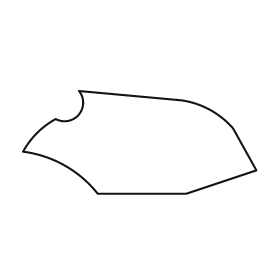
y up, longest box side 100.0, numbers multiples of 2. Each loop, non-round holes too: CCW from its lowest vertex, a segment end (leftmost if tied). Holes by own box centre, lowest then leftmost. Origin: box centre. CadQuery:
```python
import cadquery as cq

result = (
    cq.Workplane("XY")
    .moveTo(-18.0, -22.0)
    .lineTo(20.0, -22.0)
    .lineTo(50.0, -12.0)
    .lineTo(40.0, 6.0)
    .threePointArc((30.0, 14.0), (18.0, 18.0))
    .lineTo(-26.0, 22.0)
    .threePointArc((-26.0, 12.0), (-36.0, 10.0))
    .threePointArc((-44.0, 4.0), (-50.0, -4.0))
    .threePointArc((-32.0, -10.0), (-18.0, -22.0))
    .close()
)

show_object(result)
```